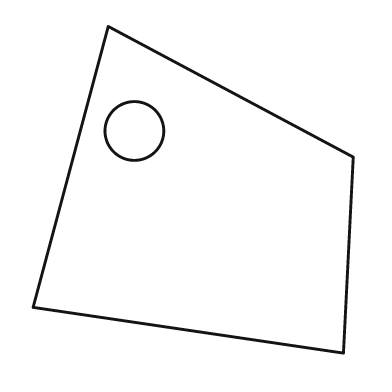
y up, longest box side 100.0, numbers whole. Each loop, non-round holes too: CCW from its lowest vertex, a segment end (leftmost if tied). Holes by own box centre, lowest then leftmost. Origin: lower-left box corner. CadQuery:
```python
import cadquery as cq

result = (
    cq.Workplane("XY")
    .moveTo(95.0, 0.0)
    .lineTo(98.0, 60.0)
    .lineTo(23.0, 100.0)
    .lineTo(0.0, 14.0)
    .close()
    .moveTo(31.0, 68.0)
    .circle(9.0)
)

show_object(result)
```